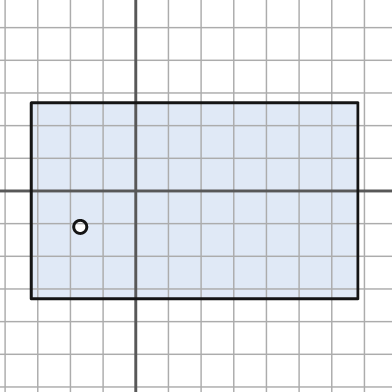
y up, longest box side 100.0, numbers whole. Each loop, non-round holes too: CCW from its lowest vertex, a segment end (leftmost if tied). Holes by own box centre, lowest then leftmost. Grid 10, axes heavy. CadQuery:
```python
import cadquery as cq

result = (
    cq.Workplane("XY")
    .moveTo(-32.0, -33.0)
    .lineTo(68.0, -33.0)
    .lineTo(68.0, 27.0)
    .lineTo(-32.0, 27.0)
    .close()
    .moveTo(-17.0, -11.0)
    .circle(2.0)
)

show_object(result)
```